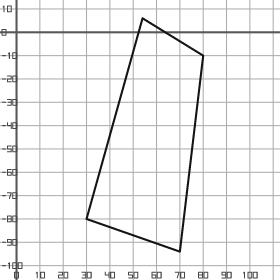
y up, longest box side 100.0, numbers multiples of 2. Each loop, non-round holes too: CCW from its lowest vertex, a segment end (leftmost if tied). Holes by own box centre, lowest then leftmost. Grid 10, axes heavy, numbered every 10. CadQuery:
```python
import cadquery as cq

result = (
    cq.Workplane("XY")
    .moveTo(70.0, -94.0)
    .lineTo(80.0, -10.0)
    .lineTo(54.0, 6.0)
    .lineTo(30.0, -80.0)
    .close()
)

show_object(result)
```